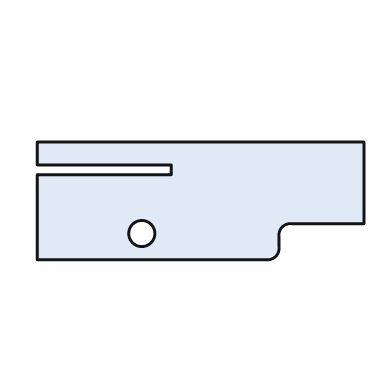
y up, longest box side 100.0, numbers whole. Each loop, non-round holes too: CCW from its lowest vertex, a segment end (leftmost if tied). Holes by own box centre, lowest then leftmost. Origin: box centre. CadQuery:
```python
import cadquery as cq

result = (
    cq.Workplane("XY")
    .moveTo(-50.0, -18.0)
    .lineTo(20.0, -18.0)
    .threePointArc((23.0, -17.0), (24.0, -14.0))
    .lineTo(24.0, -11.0)
    .threePointArc((25.0, -8.0), (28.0, -7.0))
    .lineTo(50.0, -7.0)
    .lineTo(50.0, 18.0)
    .lineTo(-50.0, 18.0)
    .lineTo(-50.0, 11.0)
    .lineTo(-9.0, 11.0)
    .lineTo(-9.0, 8.0)
    .lineTo(-50.0, 8.0)
    .close()
    .moveTo(-18.0, -10.0)
    .circle(4.0)
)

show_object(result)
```